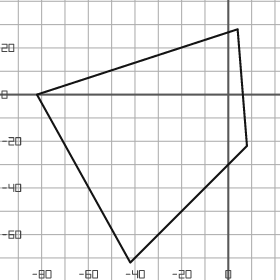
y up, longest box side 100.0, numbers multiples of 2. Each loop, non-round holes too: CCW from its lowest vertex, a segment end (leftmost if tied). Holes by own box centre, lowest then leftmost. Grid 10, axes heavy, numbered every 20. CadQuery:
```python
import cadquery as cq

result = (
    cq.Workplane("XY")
    .moveTo(-42.0, -72.0)
    .lineTo(8.0, -22.0)
    .lineTo(4.0, 28.0)
    .lineTo(-82.0, 0.0)
    .close()
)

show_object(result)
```